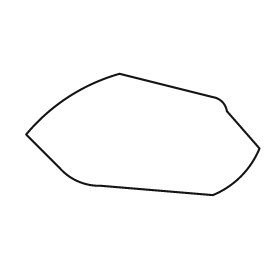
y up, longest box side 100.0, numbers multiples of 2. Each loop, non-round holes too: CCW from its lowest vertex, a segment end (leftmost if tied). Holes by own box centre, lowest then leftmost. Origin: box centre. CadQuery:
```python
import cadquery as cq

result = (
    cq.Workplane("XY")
    .moveTo(30.0, -26.0)
    .threePointArc((42.0, -18.0), (50.0, -6.0))
    .lineTo(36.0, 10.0)
    .threePointArc((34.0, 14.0), (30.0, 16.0))
    .lineTo(-10.0, 26.0)
    .threePointArc((-32.0, 16.0), (-50.0, 0.0))
    .lineTo(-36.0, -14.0)
    .threePointArc((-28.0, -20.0), (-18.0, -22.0))
    .close()
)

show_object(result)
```